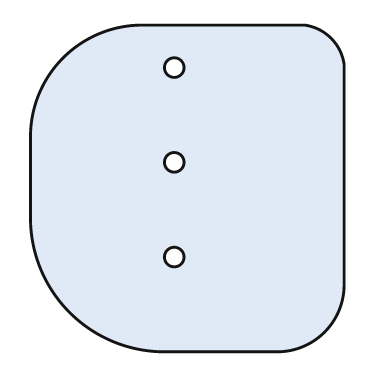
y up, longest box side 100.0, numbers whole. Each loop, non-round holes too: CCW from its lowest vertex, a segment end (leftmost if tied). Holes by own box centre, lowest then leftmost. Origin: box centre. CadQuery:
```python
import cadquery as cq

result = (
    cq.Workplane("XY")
    .moveTo(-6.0, -50.0)
    .lineTo(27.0, -50.0)
    .threePointArc((42.0, -44.0), (48.0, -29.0))
    .lineTo(48.0, 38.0)
    .threePointArc((44.0, 46.0), (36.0, 50.0))
    .lineTo(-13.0, 50.0)
    .threePointArc((-38.0, 40.0), (-48.0, 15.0))
    .lineTo(-48.0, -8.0)
    .threePointArc((-36.0, -38.0), (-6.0, -50.0))
    .close()
    .moveTo(-4.0, -21.0)
    .circle(3.0)
    .moveTo(-4.0, 8.0)
    .circle(3.0)
    .moveTo(-4.0, 37.0)
    .circle(3.0)
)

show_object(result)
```